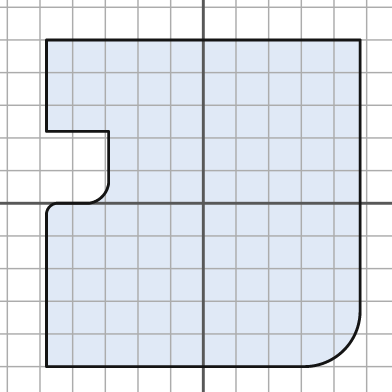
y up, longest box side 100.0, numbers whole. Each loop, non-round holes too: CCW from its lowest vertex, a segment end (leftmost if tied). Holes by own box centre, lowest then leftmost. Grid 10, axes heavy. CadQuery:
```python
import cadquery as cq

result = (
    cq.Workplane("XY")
    .moveTo(-48.0, -50.0)
    .lineTo(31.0, -50.0)
    .threePointArc((43.0, -45.0), (48.0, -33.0))
    .lineTo(48.0, 50.0)
    .lineTo(-48.0, 50.0)
    .lineTo(-48.0, 22.0)
    .lineTo(-29.0, 22.0)
    .lineTo(-29.0, 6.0)
    .threePointArc((-31.0, 2.0), (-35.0, 0.0))
    .lineTo(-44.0, 0.0)
    .threePointArc((-47.0, -1.0), (-48.0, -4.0))
    .close()
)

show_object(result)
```